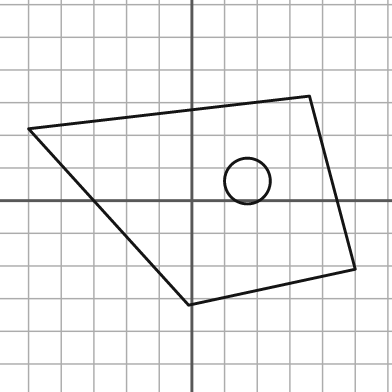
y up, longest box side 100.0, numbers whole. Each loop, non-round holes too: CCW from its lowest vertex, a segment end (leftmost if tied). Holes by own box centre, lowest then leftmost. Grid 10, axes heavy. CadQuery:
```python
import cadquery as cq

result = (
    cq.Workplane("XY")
    .moveTo(-1.0, -32.0)
    .lineTo(50.0, -21.0)
    .lineTo(36.0, 32.0)
    .lineTo(-50.0, 22.0)
    .close()
    .moveTo(17.0, 6.0)
    .circle(7.0)
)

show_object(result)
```